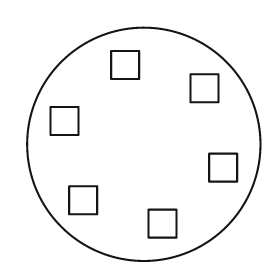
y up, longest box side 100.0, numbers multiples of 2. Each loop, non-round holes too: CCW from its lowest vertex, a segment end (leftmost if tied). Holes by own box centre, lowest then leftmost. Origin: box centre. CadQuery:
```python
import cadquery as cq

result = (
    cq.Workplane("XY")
    .moveTo(0.0, 0.0)
    .circle(50.0)
    .moveTo(2.0, -40.0)
    .lineTo(14.0, -40.0)
    .lineTo(14.0, -28.0)
    .lineTo(2.0, -28.0)
    .close()
    .moveTo(-32.0, -30.0)
    .lineTo(-20.0, -30.0)
    .lineTo(-20.0, -18.0)
    .lineTo(-32.0, -18.0)
    .close()
    .moveTo(28.0, -16.0)
    .lineTo(40.0, -16.0)
    .lineTo(40.0, -4.0)
    .lineTo(28.0, -4.0)
    .close()
    .moveTo(-40.0, 4.0)
    .lineTo(-28.0, 4.0)
    .lineTo(-28.0, 16.0)
    .lineTo(-40.0, 16.0)
    .close()
    .moveTo(20.0, 18.0)
    .lineTo(32.0, 18.0)
    .lineTo(32.0, 30.0)
    .lineTo(20.0, 30.0)
    .close()
    .moveTo(-14.0, 28.0)
    .lineTo(-2.0, 28.0)
    .lineTo(-2.0, 40.0)
    .lineTo(-14.0, 40.0)
    .close()
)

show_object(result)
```